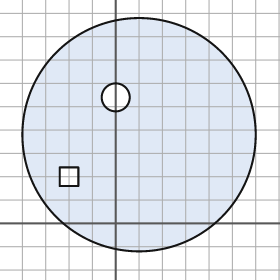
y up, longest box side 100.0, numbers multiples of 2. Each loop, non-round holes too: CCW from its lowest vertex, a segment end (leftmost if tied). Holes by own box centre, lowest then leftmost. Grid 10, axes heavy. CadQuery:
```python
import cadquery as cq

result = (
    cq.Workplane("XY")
    .moveTo(10.0, 38.0)
    .circle(50.0)
    .moveTo(-24.0, 16.0)
    .lineTo(-16.0, 16.0)
    .lineTo(-16.0, 24.0)
    .lineTo(-24.0, 24.0)
    .close()
    .moveTo(0.0, 54.0)
    .circle(6.0)
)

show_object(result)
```